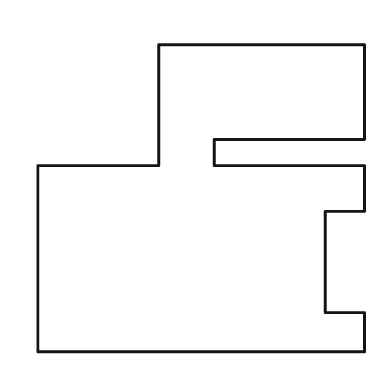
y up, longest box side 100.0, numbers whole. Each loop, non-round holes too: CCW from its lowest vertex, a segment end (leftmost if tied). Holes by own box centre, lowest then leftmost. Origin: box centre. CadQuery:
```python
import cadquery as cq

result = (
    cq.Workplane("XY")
    .moveTo(-50.0, -47.0)
    .lineTo(50.0, -47.0)
    .lineTo(50.0, -35.0)
    .lineTo(38.0, -35.0)
    .lineTo(38.0, -4.0)
    .lineTo(50.0, -4.0)
    .lineTo(50.0, 10.0)
    .lineTo(4.0, 10.0)
    .lineTo(4.0, 18.0)
    .lineTo(50.0, 18.0)
    .lineTo(50.0, 47.0)
    .lineTo(-13.0, 47.0)
    .lineTo(-13.0, 10.0)
    .lineTo(-50.0, 10.0)
    .close()
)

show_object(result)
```